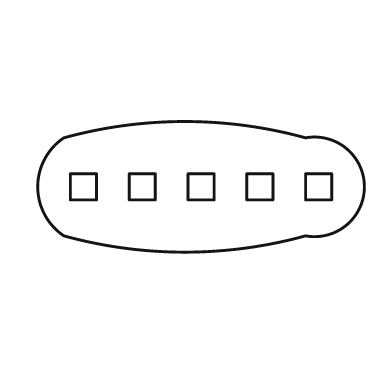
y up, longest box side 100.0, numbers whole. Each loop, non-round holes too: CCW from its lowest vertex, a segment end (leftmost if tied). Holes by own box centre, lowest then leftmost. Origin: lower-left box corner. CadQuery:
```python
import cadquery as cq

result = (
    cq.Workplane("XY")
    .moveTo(8.0, 5.0)
    .threePointArc((45.0, 0.0), (82.0, 5.0))
    .threePointArc((100.0, 20.0), (82.0, 35.0))
    .threePointArc((45.0, 40.0), (8.0, 35.0))
    .threePointArc((0.0, 20.0), (8.0, 5.0))
    .close()
    .moveTo(10.0, 16.0)
    .lineTo(18.0, 16.0)
    .lineTo(18.0, 24.0)
    .lineTo(10.0, 24.0)
    .close()
    .moveTo(28.0, 16.0)
    .lineTo(36.0, 16.0)
    .lineTo(36.0, 24.0)
    .lineTo(28.0, 24.0)
    .close()
    .moveTo(46.0, 16.0)
    .lineTo(54.0, 16.0)
    .lineTo(54.0, 24.0)
    .lineTo(46.0, 24.0)
    .close()
    .moveTo(64.0, 16.0)
    .lineTo(72.0, 16.0)
    .lineTo(72.0, 24.0)
    .lineTo(64.0, 24.0)
    .close()
    .moveTo(82.0, 16.0)
    .lineTo(90.0, 16.0)
    .lineTo(90.0, 24.0)
    .lineTo(82.0, 24.0)
    .close()
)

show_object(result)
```